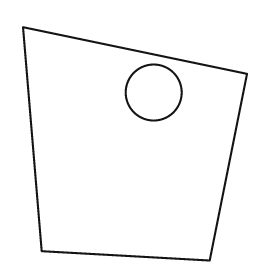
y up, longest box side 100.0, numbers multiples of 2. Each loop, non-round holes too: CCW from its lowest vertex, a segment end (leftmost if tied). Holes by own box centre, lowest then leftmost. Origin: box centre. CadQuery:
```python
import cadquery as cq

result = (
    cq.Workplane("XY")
    .moveTo(32.0, -50.0)
    .lineTo(48.0, 30.0)
    .lineTo(-48.0, 50.0)
    .lineTo(-40.0, -46.0)
    .close()
    .moveTo(8.0, 22.0)
    .circle(12.0)
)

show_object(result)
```